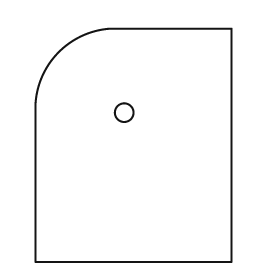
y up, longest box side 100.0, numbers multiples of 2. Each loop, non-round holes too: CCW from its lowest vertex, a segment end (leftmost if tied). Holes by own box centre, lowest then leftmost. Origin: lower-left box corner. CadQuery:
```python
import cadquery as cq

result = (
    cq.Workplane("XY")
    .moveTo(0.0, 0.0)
    .lineTo(84.0, 0.0)
    .lineTo(84.0, 100.0)
    .lineTo(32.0, 100.0)
    .threePointArc((10.0, 90.0), (0.0, 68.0))
    .close()
    .moveTo(38.0, 64.0)
    .circle(4.0)
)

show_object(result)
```